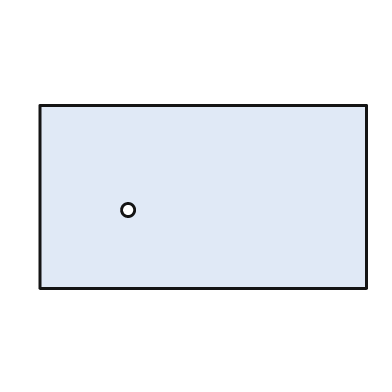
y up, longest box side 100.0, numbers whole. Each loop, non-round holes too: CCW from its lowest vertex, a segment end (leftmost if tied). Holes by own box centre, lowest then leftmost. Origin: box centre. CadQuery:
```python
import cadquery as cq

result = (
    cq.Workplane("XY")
    .moveTo(-50.0, -28.0)
    .lineTo(50.0, -28.0)
    .lineTo(50.0, 28.0)
    .lineTo(-50.0, 28.0)
    .close()
    .moveTo(-23.0, -4.0)
    .circle(2.0)
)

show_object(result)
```